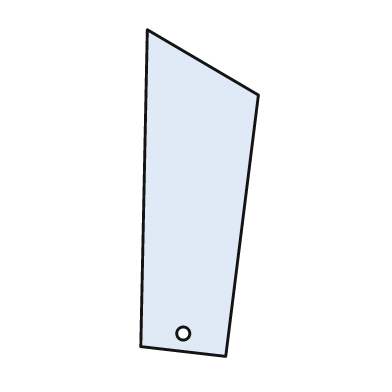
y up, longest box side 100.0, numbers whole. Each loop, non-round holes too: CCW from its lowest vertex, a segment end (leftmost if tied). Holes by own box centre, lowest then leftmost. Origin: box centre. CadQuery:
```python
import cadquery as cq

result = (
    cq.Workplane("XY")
    .moveTo(8.0, -50.0)
    .lineTo(18.0, 30.0)
    .lineTo(-16.0, 50.0)
    .lineTo(-18.0, -47.0)
    .close()
    .moveTo(-5.0, -43.0)
    .circle(2.0)
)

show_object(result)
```